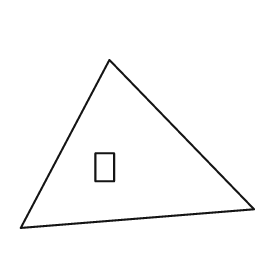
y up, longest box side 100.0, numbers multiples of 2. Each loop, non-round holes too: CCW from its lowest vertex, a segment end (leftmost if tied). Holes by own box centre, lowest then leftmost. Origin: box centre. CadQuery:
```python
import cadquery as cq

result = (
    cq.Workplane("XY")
    .moveTo(-50.0, -36.0)
    .lineTo(50.0, -28.0)
    .lineTo(-12.0, 36.0)
    .close()
    .moveTo(-18.0, -16.0)
    .lineTo(-10.0, -16.0)
    .lineTo(-10.0, -4.0)
    .lineTo(-18.0, -4.0)
    .close()
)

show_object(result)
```